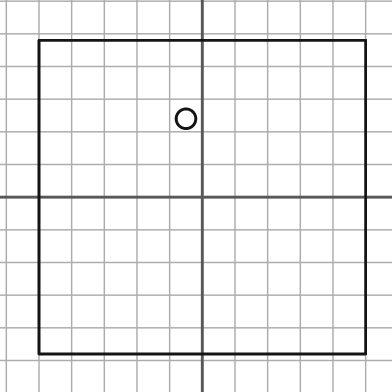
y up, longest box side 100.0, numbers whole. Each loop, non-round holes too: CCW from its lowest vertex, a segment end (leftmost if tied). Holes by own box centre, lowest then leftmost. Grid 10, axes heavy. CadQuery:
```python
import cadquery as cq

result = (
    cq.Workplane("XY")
    .moveTo(-50.0, -48.0)
    .lineTo(50.0, -48.0)
    .lineTo(50.0, 48.0)
    .lineTo(-50.0, 48.0)
    .close()
    .moveTo(-5.0, 24.0)
    .circle(3.0)
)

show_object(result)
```